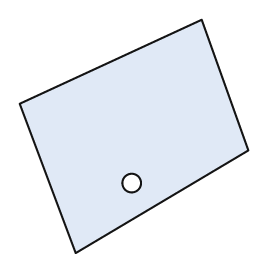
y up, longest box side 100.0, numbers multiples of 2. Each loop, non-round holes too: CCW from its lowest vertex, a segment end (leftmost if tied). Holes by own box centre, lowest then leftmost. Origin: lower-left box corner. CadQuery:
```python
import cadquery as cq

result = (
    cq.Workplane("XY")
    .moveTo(24.0, 0.0)
    .lineTo(98.0, 44.0)
    .lineTo(78.0, 100.0)
    .lineTo(0.0, 64.0)
    .close()
    .moveTo(48.0, 30.0)
    .circle(4.0)
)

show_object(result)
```